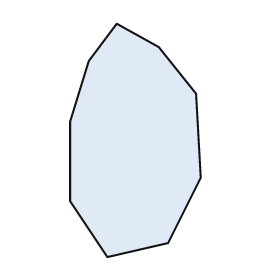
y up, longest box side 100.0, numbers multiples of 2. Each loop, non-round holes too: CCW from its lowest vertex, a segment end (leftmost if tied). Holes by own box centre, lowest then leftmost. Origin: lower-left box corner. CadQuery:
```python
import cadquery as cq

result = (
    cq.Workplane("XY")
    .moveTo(16.0, 0.0)
    .lineTo(42.0, 6.0)
    .lineTo(56.0, 34.0)
    .lineTo(54.0, 70.0)
    .lineTo(38.0, 90.0)
    .lineTo(20.0, 100.0)
    .lineTo(8.0, 84.0)
    .lineTo(0.0, 58.0)
    .lineTo(0.0, 24.0)
    .close()
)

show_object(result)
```